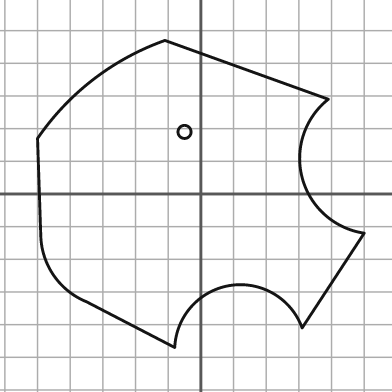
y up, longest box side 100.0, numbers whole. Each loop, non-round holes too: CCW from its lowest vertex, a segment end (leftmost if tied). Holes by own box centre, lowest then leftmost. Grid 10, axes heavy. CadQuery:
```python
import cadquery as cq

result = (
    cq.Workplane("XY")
    .moveTo(-8.0, -47.0)
    .threePointArc((9.0, -28.0), (31.0, -41.0))
    .lineTo(50.0, -12.0)
    .threePointArc((31.0, 5.0), (39.0, 29.0))
    .lineTo(-11.0, 47.0)
    .threePointArc((-33.0, 35.0), (-50.0, 17.0))
    .lineTo(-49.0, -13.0)
    .threePointArc((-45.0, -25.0), (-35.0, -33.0))
    .close()
    .moveTo(-5.0, 19.0)
    .circle(2.0)
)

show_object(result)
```